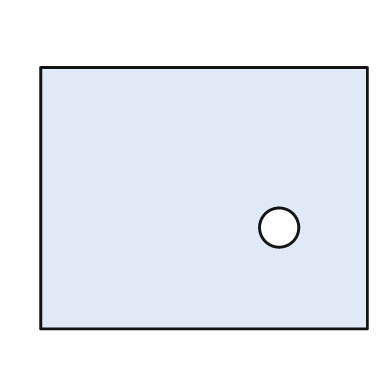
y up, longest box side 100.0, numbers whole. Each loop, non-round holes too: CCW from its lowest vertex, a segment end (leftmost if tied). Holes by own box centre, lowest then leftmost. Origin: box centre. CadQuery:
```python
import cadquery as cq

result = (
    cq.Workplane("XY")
    .moveTo(-50.0, -40.0)
    .lineTo(50.0, -40.0)
    .lineTo(50.0, 40.0)
    .lineTo(-50.0, 40.0)
    .close()
    .moveTo(23.0, -9.0)
    .circle(6.0)
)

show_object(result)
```